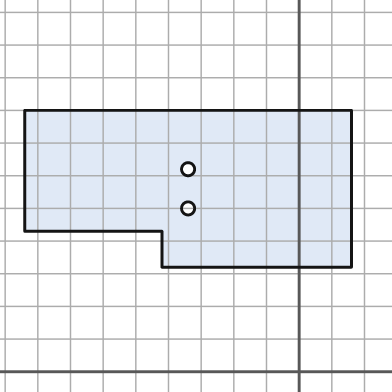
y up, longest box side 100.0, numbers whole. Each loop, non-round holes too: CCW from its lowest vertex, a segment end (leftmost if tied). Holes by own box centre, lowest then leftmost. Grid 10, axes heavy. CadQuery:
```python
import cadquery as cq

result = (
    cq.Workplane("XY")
    .moveTo(-42.0, 32.0)
    .lineTo(16.0, 32.0)
    .lineTo(16.0, 80.0)
    .lineTo(-84.0, 80.0)
    .lineTo(-84.0, 43.0)
    .lineTo(-42.0, 43.0)
    .close()
    .moveTo(-34.0, 50.0)
    .circle(2.0)
    .moveTo(-34.0, 62.0)
    .circle(2.0)
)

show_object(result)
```